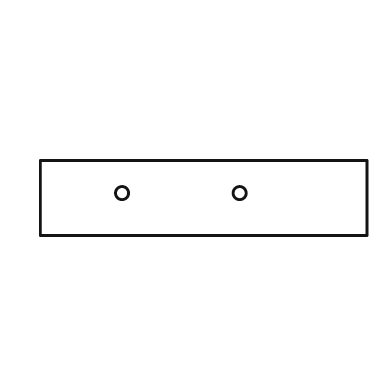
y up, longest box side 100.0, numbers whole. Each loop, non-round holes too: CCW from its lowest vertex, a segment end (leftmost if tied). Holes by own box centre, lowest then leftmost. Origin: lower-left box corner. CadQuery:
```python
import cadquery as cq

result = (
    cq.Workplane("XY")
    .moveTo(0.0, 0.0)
    .lineTo(100.0, 0.0)
    .lineTo(100.0, 23.0)
    .lineTo(0.0, 23.0)
    .close()
    .moveTo(25.0, 13.0)
    .circle(2.0)
    .moveTo(61.0, 13.0)
    .circle(2.0)
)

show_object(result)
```